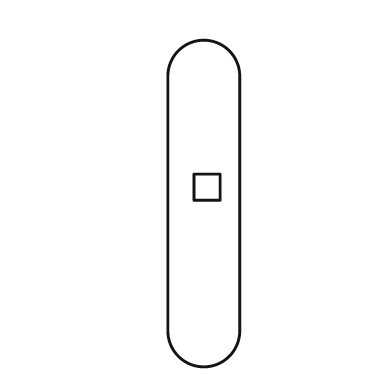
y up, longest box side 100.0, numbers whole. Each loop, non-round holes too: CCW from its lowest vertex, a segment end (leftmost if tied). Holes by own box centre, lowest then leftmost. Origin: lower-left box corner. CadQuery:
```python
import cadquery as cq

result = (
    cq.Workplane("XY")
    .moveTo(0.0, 11.0)
    .threePointArc((11.0, 0.0), (22.0, 11.0))
    .lineTo(22.0, 89.0)
    .threePointArc((11.0, 100.0), (0.0, 89.0))
    .close()
    .moveTo(8.0, 51.0)
    .lineTo(16.0, 51.0)
    .lineTo(16.0, 59.0)
    .lineTo(8.0, 59.0)
    .close()
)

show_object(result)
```